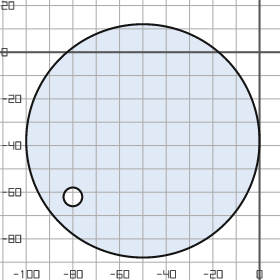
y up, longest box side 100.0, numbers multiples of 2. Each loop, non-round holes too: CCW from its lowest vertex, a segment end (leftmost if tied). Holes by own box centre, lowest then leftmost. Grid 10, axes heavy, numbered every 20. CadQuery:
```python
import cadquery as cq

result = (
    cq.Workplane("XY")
    .moveTo(-50.0, -38.0)
    .circle(50.0)
    .moveTo(-80.0, -62.0)
    .circle(4.0)
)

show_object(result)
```